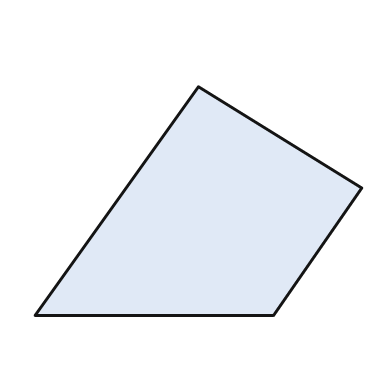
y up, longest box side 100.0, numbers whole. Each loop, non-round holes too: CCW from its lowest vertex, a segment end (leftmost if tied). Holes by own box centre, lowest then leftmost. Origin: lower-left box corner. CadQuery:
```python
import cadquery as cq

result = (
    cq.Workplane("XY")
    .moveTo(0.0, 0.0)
    .lineTo(73.0, 0.0)
    .lineTo(100.0, 39.0)
    .lineTo(50.0, 70.0)
    .close()
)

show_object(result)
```